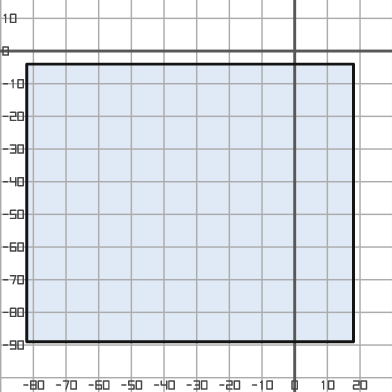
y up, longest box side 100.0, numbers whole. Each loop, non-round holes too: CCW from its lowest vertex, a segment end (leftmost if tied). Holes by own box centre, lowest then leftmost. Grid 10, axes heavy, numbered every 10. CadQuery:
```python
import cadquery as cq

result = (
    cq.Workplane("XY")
    .moveTo(-82.0, -89.0)
    .lineTo(18.0, -89.0)
    .lineTo(18.0, -4.0)
    .lineTo(-82.0, -4.0)
    .close()
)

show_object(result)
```